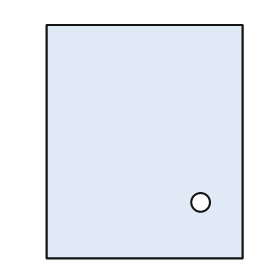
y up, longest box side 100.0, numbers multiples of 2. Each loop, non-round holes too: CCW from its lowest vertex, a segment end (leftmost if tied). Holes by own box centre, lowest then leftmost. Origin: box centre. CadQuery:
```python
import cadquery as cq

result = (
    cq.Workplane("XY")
    .moveTo(-42.0, -50.0)
    .lineTo(42.0, -50.0)
    .lineTo(42.0, 50.0)
    .lineTo(-42.0, 50.0)
    .close()
    .moveTo(24.0, -26.0)
    .circle(4.0)
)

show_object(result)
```